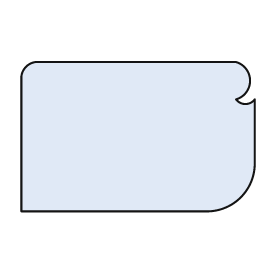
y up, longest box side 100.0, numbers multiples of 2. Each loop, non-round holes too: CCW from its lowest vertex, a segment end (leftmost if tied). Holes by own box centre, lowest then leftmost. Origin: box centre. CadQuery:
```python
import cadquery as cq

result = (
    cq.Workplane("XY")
    .moveTo(-50.0, -32.0)
    .lineTo(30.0, -32.0)
    .threePointArc((44.0, -26.0), (50.0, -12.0))
    .lineTo(50.0, 16.0)
    .threePointArc((46.0, 14.0), (42.0, 16.0))
    .threePointArc((48.0, 24.0), (42.0, 32.0))
    .lineTo(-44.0, 32.0)
    .threePointArc((-48.0, 30.0), (-50.0, 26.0))
    .close()
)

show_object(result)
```